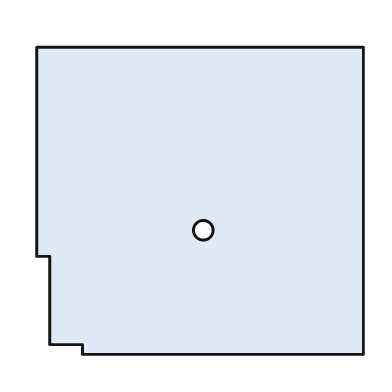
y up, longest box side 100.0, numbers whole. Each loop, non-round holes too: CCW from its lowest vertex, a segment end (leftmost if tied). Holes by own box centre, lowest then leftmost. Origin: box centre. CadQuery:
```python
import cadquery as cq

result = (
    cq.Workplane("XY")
    .moveTo(-36.0, -47.0)
    .lineTo(50.0, -47.0)
    .lineTo(50.0, 47.0)
    .lineTo(-50.0, 47.0)
    .lineTo(-50.0, -17.0)
    .lineTo(-46.0, -17.0)
    .lineTo(-46.0, -44.0)
    .lineTo(-36.0, -44.0)
    .close()
    .moveTo(1.0, -9.0)
    .circle(3.0)
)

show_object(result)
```